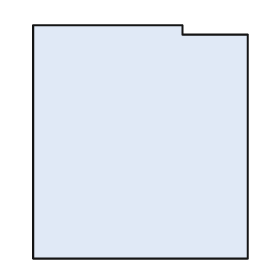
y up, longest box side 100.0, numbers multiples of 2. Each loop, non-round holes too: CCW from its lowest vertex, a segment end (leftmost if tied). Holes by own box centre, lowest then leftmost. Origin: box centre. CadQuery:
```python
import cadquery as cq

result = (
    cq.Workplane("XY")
    .moveTo(-46.0, -50.0)
    .lineTo(46.0, -50.0)
    .lineTo(46.0, 46.0)
    .lineTo(18.0, 46.0)
    .lineTo(18.0, 50.0)
    .lineTo(-46.0, 50.0)
    .close()
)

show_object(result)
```